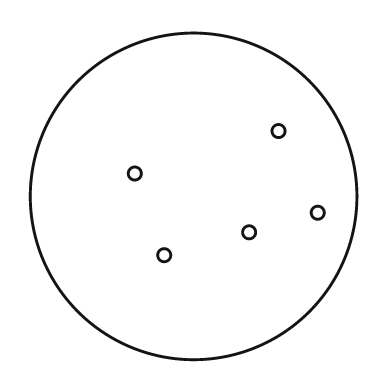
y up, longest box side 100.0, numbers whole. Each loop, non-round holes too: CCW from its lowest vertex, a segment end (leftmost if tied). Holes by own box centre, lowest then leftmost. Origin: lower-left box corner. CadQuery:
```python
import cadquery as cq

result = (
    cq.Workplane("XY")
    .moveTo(50.0, 50.0)
    .circle(50.0)
    .moveTo(41.0, 32.0)
    .circle(2.0)
    .moveTo(67.0, 39.0)
    .circle(2.0)
    .moveTo(88.0, 45.0)
    .circle(2.0)
    .moveTo(32.0, 57.0)
    .circle(2.0)
    .moveTo(76.0, 70.0)
    .circle(2.0)
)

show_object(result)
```